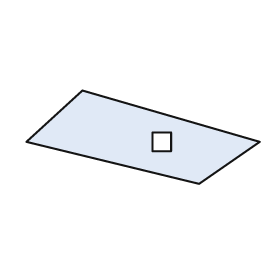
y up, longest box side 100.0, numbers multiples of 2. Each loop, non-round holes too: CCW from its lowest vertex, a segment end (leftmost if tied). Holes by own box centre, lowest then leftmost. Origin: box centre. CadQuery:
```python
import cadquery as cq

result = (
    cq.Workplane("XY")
    .moveTo(24.0, -20.0)
    .lineTo(50.0, -2.0)
    .lineTo(-26.0, 20.0)
    .lineTo(-50.0, -2.0)
    .close()
    .moveTo(4.0, -6.0)
    .lineTo(12.0, -6.0)
    .lineTo(12.0, 2.0)
    .lineTo(4.0, 2.0)
    .close()
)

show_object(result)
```